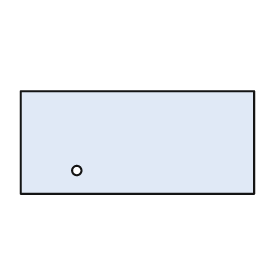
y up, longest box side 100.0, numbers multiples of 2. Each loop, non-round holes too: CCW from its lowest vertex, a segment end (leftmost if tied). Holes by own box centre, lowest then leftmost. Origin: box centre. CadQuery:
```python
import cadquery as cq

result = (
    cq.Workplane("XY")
    .moveTo(-50.0, -22.0)
    .lineTo(50.0, -22.0)
    .lineTo(50.0, 22.0)
    .lineTo(-50.0, 22.0)
    .close()
    .moveTo(-26.0, -12.0)
    .circle(2.0)
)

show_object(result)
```